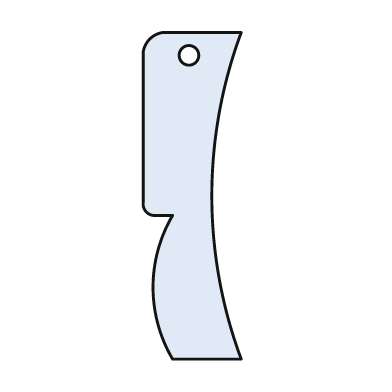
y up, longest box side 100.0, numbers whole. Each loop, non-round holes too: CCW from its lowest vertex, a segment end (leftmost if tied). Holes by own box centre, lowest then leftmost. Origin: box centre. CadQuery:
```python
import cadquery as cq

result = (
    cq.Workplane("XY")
    .moveTo(-6.0, -50.0)
    .lineTo(15.0, -50.0)
    .threePointArc((6.0, 0.0), (15.0, 50.0))
    .lineTo(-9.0, 50.0)
    .threePointArc((-13.0, 48.0), (-15.0, 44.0))
    .lineTo(-15.0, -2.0)
    .threePointArc((-14.0, -5.0), (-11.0, -6.0))
    .lineTo(-6.0, -6.0)
    .threePointArc((-12.0, -28.0), (-6.0, -50.0))
    .close()
    .moveTo(-1.0, 43.0)
    .circle(3.0)
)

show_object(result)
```